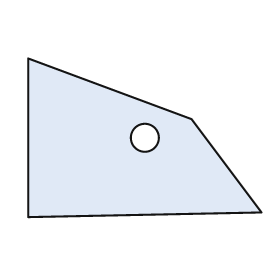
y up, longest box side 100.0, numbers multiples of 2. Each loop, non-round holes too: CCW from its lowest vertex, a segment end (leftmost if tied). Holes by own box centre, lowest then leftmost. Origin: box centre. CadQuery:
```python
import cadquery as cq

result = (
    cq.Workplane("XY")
    .moveTo(-50.0, -34.0)
    .lineTo(50.0, -32.0)
    .lineTo(20.0, 8.0)
    .lineTo(-50.0, 34.0)
    .close()
    .moveTo(0.0, 0.0)
    .circle(6.0)
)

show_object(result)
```